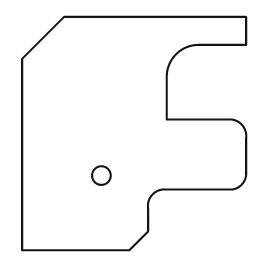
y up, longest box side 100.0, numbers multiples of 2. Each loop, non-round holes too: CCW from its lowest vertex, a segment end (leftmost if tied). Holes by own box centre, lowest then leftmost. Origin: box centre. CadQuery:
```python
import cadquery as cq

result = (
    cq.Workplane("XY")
    .moveTo(-48.0, -50.0)
    .lineTo(-2.0, -50.0)
    .lineTo(6.0, -42.0)
    .lineTo(6.0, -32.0)
    .threePointArc((8.0, -26.0), (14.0, -24.0))
    .lineTo(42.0, -24.0)
    .threePointArc((46.0, -22.0), (48.0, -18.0))
    .lineTo(48.0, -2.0)
    .threePointArc((46.0, 4.0), (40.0, 6.0))
    .lineTo(14.0, 6.0)
    .lineTo(14.0, 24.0)
    .threePointArc((18.0, 34.0), (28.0, 38.0))
    .lineTo(48.0, 38.0)
    .lineTo(48.0, 50.0)
    .lineTo(-30.0, 50.0)
    .lineTo(-48.0, 32.0)
    .close()
    .moveTo(-14.0, -18.0)
    .circle(4.0)
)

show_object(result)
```